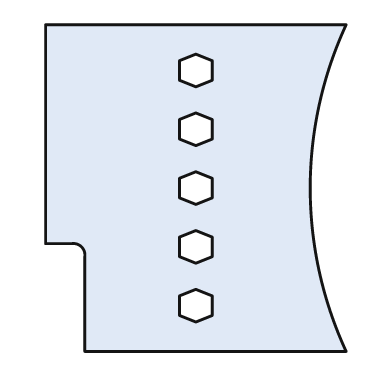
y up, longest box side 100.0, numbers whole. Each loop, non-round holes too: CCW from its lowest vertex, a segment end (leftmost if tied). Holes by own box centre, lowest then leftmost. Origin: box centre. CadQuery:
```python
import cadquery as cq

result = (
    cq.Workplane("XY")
    .moveTo(-34.0, -50.0)
    .lineTo(46.0, -50.0)
    .threePointArc((35.0, 0.0), (46.0, 50.0))
    .lineTo(-46.0, 50.0)
    .lineTo(-46.0, -17.0)
    .lineTo(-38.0, -17.0)
    .threePointArc((-35.0, -18.0), (-34.0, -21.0))
    .close()
    .moveTo(0.0, -41.0)
    .lineTo(5.0, -39.0)
    .lineTo(5.0, -33.0)
    .lineTo(0.0, -31.0)
    .lineTo(-5.0, -33.0)
    .lineTo(-5.0, -39.0)
    .close()
    .moveTo(0.0, -23.0)
    .lineTo(5.0, -21.0)
    .lineTo(5.0, -15.0)
    .lineTo(0.0, -13.0)
    .lineTo(-5.0, -15.0)
    .lineTo(-5.0, -21.0)
    .close()
    .moveTo(0.0, -5.0)
    .lineTo(5.0, -3.0)
    .lineTo(5.0, 3.0)
    .lineTo(0.0, 5.0)
    .lineTo(-5.0, 3.0)
    .lineTo(-5.0, -3.0)
    .close()
    .moveTo(0.0, 13.0)
    .lineTo(5.0, 15.0)
    .lineTo(5.0, 21.0)
    .lineTo(0.0, 23.0)
    .lineTo(-5.0, 21.0)
    .lineTo(-5.0, 15.0)
    .close()
    .moveTo(0.0, 31.0)
    .lineTo(5.0, 33.0)
    .lineTo(5.0, 39.0)
    .lineTo(0.0, 41.0)
    .lineTo(-5.0, 39.0)
    .lineTo(-5.0, 33.0)
    .close()
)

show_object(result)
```